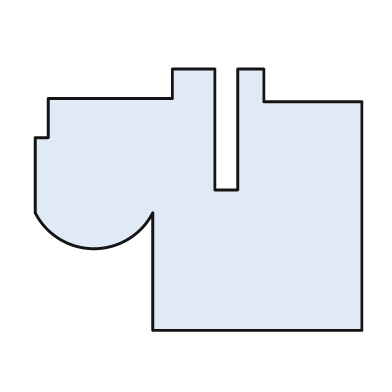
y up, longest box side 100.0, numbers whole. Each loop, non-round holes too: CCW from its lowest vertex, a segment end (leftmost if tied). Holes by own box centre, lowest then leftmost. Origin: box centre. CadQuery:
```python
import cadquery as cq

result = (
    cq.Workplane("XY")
    .moveTo(-14.0, -40.0)
    .lineTo(50.0, -40.0)
    .lineTo(50.0, 30.0)
    .lineTo(20.0, 30.0)
    .lineTo(20.0, 40.0)
    .lineTo(12.0, 40.0)
    .lineTo(12.0, 3.0)
    .lineTo(5.0, 3.0)
    .lineTo(5.0, 40.0)
    .lineTo(-8.0, 40.0)
    .lineTo(-8.0, 31.0)
    .lineTo(-46.0, 31.0)
    .lineTo(-46.0, 19.0)
    .lineTo(-50.0, 19.0)
    .lineTo(-50.0, -4.0)
    .threePointArc((-32.0, -15.0), (-14.0, -4.0))
    .close()
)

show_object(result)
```